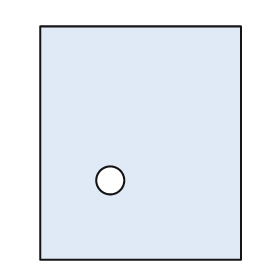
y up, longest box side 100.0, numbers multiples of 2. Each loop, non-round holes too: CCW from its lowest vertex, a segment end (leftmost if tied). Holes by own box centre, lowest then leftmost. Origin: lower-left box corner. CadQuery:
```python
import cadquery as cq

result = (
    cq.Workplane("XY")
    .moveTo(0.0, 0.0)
    .lineTo(86.0, 0.0)
    .lineTo(86.0, 100.0)
    .lineTo(0.0, 100.0)
    .close()
    .moveTo(30.0, 34.0)
    .circle(6.0)
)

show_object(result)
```